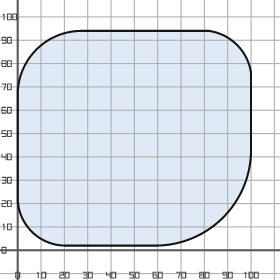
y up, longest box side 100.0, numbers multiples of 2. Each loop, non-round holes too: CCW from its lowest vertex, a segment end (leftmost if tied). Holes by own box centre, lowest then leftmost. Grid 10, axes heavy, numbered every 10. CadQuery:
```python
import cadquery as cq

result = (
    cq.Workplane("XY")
    .moveTo(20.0, 2.0)
    .lineTo(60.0, 2.0)
    .threePointArc((88.0, 14.0), (100.0, 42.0))
    .lineTo(100.0, 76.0)
    .threePointArc((94.0, 88.0), (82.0, 94.0))
    .lineTo(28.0, 94.0)
    .threePointArc((8.0, 86.0), (0.0, 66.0))
    .lineTo(0.0, 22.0)
    .threePointArc((6.0, 8.0), (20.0, 2.0))
    .close()
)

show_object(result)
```